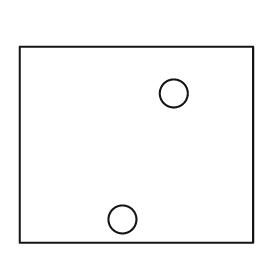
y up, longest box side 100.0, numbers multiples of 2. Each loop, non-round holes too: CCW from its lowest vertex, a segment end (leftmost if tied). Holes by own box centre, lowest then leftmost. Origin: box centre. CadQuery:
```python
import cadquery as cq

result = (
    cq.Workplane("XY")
    .moveTo(-50.0, -42.0)
    .lineTo(50.0, -42.0)
    .lineTo(50.0, 42.0)
    .lineTo(-50.0, 42.0)
    .close()
    .moveTo(-6.0, -32.0)
    .circle(6.0)
    .moveTo(16.0, 22.0)
    .circle(6.0)
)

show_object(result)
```